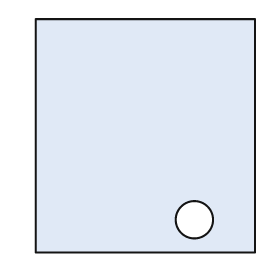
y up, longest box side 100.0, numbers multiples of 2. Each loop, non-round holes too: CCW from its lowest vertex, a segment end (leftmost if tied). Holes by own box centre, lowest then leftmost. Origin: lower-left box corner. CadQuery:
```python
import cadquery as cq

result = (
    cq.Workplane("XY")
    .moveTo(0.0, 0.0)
    .lineTo(94.0, 0.0)
    .lineTo(94.0, 100.0)
    .lineTo(0.0, 100.0)
    .close()
    .moveTo(68.0, 14.0)
    .circle(8.0)
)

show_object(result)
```